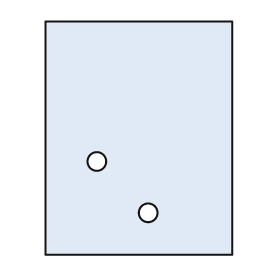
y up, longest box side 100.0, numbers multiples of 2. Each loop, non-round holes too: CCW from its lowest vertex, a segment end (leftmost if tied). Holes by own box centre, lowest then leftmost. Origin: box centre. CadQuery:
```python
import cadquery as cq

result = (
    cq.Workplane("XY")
    .moveTo(-40.0, -50.0)
    .lineTo(40.0, -50.0)
    .lineTo(40.0, 50.0)
    .lineTo(-40.0, 50.0)
    .close()
    .moveTo(4.0, -32.0)
    .circle(4.0)
    .moveTo(-18.0, -10.0)
    .circle(4.0)
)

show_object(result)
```